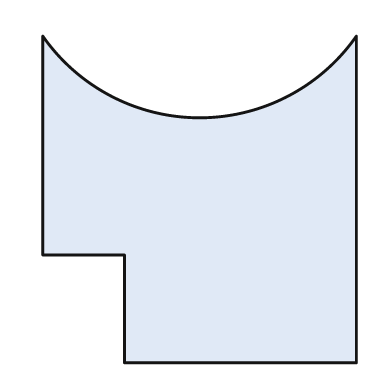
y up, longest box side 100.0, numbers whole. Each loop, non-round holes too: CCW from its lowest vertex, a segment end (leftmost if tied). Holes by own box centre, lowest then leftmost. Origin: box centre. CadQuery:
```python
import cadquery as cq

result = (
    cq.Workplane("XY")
    .moveTo(-23.0, -50.0)
    .lineTo(48.0, -50.0)
    .lineTo(48.0, 50.0)
    .threePointArc((0.0, 25.0), (-48.0, 50.0))
    .lineTo(-48.0, -17.0)
    .lineTo(-23.0, -17.0)
    .close()
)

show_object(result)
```